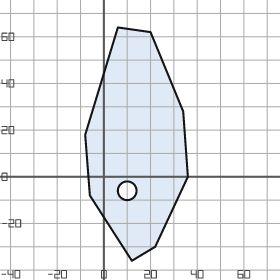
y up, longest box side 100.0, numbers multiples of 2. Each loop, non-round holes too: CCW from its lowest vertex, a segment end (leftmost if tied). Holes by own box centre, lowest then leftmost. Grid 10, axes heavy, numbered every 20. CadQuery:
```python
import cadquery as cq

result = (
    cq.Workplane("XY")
    .moveTo(12.0, -36.0)
    .lineTo(22.0, -30.0)
    .lineTo(36.0, 0.0)
    .lineTo(34.0, 28.0)
    .lineTo(20.0, 62.0)
    .lineTo(6.0, 64.0)
    .lineTo(-8.0, 18.0)
    .lineTo(-6.0, -8.0)
    .close()
    .moveTo(10.0, -6.0)
    .circle(4.0)
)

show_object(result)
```